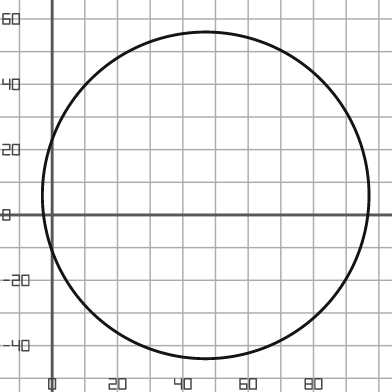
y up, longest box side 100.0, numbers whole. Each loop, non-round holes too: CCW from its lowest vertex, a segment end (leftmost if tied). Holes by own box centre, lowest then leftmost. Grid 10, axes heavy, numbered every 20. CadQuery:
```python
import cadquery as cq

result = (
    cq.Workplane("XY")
    .moveTo(47.0, 6.0)
    .circle(50.0)
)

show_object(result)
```